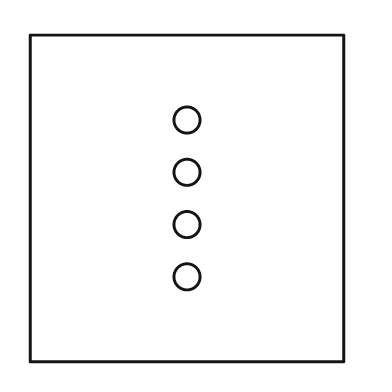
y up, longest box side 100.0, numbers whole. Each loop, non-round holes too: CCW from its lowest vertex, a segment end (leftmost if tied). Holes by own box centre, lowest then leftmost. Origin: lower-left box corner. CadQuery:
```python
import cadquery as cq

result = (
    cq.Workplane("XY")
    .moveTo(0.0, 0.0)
    .lineTo(96.0, 0.0)
    .lineTo(96.0, 100.0)
    .lineTo(0.0, 100.0)
    .close()
    .moveTo(48.0, 26.0)
    .circle(4.0)
    .moveTo(48.0, 42.0)
    .circle(4.0)
    .moveTo(48.0, 58.0)
    .circle(4.0)
    .moveTo(48.0, 74.0)
    .circle(4.0)
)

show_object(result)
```